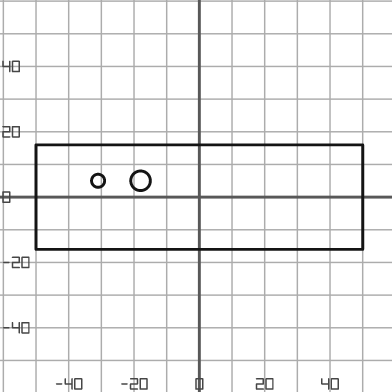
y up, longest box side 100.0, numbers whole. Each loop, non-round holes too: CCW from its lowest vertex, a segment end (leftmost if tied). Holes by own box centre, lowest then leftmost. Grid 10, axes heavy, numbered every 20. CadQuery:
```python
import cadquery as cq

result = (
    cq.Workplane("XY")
    .moveTo(-50.0, -16.0)
    .lineTo(50.0, -16.0)
    .lineTo(50.0, 16.0)
    .lineTo(-50.0, 16.0)
    .close()
    .moveTo(-31.0, 5.0)
    .circle(2.0)
    .moveTo(-18.0, 5.0)
    .circle(3.0)
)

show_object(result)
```